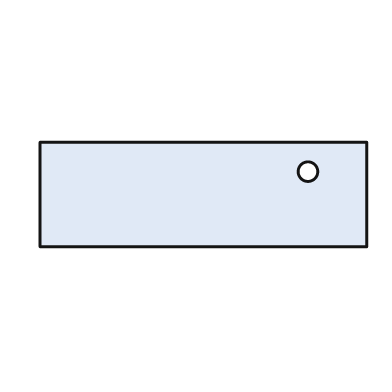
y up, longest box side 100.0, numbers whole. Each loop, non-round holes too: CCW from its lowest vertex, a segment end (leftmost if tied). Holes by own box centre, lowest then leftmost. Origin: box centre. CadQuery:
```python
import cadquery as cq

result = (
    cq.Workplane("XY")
    .moveTo(-50.0, -16.0)
    .lineTo(50.0, -16.0)
    .lineTo(50.0, 16.0)
    .lineTo(-50.0, 16.0)
    .close()
    .moveTo(32.0, 7.0)
    .circle(3.0)
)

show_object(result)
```